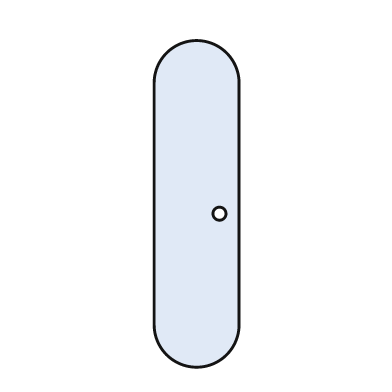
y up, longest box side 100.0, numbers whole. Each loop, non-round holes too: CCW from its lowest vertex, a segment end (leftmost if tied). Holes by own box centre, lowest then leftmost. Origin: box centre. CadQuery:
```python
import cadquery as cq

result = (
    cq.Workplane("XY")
    .moveTo(-13.0, -37.0)
    .threePointArc((0.0, -50.0), (13.0, -37.0))
    .lineTo(13.0, 37.0)
    .threePointArc((0.0, 50.0), (-13.0, 37.0))
    .close()
    .moveTo(7.0, -3.0)
    .circle(2.0)
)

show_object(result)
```